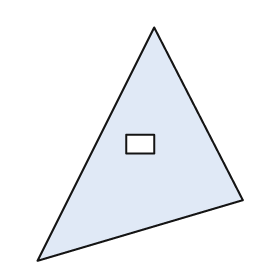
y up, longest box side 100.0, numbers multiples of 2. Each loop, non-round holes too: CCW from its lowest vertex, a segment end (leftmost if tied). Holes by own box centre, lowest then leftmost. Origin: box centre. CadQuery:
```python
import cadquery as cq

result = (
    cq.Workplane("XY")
    .moveTo(-44.0, -50.0)
    .lineTo(44.0, -24.0)
    .lineTo(6.0, 50.0)
    .close()
    .moveTo(-6.0, -4.0)
    .lineTo(6.0, -4.0)
    .lineTo(6.0, 4.0)
    .lineTo(-6.0, 4.0)
    .close()
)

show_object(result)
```